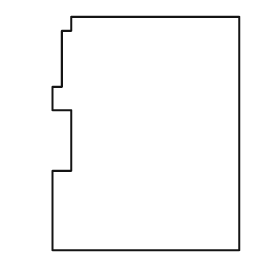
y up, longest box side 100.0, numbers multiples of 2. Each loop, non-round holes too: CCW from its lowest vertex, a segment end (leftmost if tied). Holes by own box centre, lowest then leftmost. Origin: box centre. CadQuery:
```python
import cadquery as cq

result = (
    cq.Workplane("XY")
    .moveTo(-40.0, -50.0)
    .lineTo(40.0, -50.0)
    .lineTo(40.0, 50.0)
    .lineTo(-32.0, 50.0)
    .lineTo(-32.0, 44.0)
    .lineTo(-36.0, 44.0)
    .lineTo(-36.0, 20.0)
    .lineTo(-40.0, 20.0)
    .lineTo(-40.0, 10.0)
    .lineTo(-32.0, 10.0)
    .lineTo(-32.0, -16.0)
    .lineTo(-40.0, -16.0)
    .close()
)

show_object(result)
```